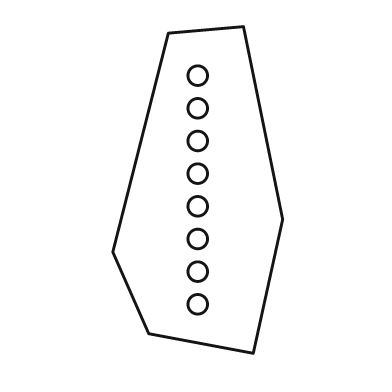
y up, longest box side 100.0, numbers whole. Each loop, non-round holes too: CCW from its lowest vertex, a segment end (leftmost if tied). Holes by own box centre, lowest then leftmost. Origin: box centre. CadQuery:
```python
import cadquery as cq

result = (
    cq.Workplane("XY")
    .moveTo(17.0, -50.0)
    .lineTo(26.0, -9.0)
    .lineTo(14.0, 50.0)
    .lineTo(-9.0, 48.0)
    .lineTo(-26.0, -19.0)
    .lineTo(-15.0, -44.0)
    .close()
    .moveTo(0.0, -35.0)
    .circle(3.0)
    .moveTo(0.0, -25.0)
    .circle(3.0)
    .moveTo(0.0, -15.0)
    .circle(3.0)
    .moveTo(0.0, -5.0)
    .circle(3.0)
    .moveTo(0.0, 5.0)
    .circle(3.0)
    .moveTo(0.0, 15.0)
    .circle(3.0)
    .moveTo(0.0, 25.0)
    .circle(3.0)
    .moveTo(0.0, 35.0)
    .circle(3.0)
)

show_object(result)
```